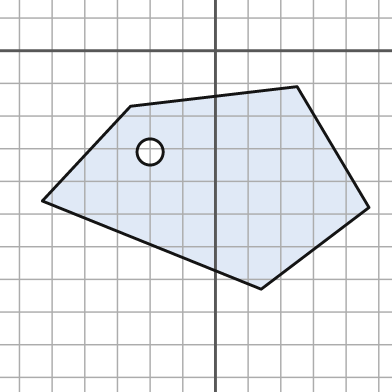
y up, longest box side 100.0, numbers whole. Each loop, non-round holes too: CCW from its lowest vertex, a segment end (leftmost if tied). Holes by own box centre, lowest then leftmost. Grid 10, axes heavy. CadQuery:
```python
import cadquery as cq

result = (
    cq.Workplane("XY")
    .moveTo(14.0, -73.0)
    .lineTo(47.0, -48.0)
    .lineTo(25.0, -11.0)
    .lineTo(-26.0, -17.0)
    .lineTo(-53.0, -46.0)
    .close()
    .moveTo(-20.0, -31.0)
    .circle(4.0)
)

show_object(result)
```